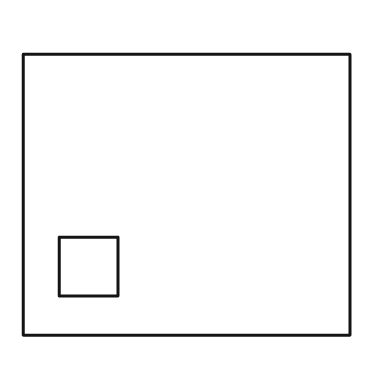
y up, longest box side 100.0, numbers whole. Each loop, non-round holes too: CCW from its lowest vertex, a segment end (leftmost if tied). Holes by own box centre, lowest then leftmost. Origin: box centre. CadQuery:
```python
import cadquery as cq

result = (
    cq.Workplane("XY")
    .moveTo(-50.0, -43.0)
    .lineTo(50.0, -43.0)
    .lineTo(50.0, 43.0)
    .lineTo(-50.0, 43.0)
    .close()
    .moveTo(-39.0, -31.0)
    .lineTo(-21.0, -31.0)
    .lineTo(-21.0, -13.0)
    .lineTo(-39.0, -13.0)
    .close()
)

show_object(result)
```